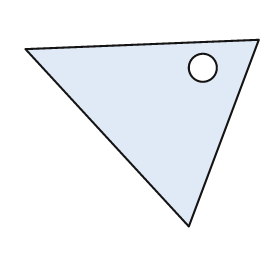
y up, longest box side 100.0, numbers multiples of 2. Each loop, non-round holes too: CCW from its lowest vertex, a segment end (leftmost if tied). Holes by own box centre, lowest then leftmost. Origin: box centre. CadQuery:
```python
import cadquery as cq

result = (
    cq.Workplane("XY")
    .moveTo(20.0, -40.0)
    .lineTo(50.0, 40.0)
    .lineTo(-50.0, 36.0)
    .close()
    .moveTo(26.0, 28.0)
    .circle(6.0)
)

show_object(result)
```